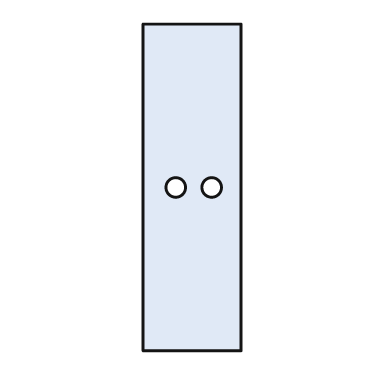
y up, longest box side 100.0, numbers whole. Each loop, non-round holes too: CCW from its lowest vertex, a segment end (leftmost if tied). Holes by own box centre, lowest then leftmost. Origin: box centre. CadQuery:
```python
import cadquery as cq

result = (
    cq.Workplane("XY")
    .moveTo(-15.0, -50.0)
    .lineTo(15.0, -50.0)
    .lineTo(15.0, 50.0)
    .lineTo(-15.0, 50.0)
    .close()
    .moveTo(-5.0, 0.0)
    .circle(3.0)
    .moveTo(6.0, 0.0)
    .circle(3.0)
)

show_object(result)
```